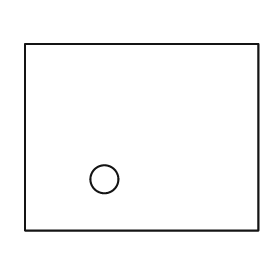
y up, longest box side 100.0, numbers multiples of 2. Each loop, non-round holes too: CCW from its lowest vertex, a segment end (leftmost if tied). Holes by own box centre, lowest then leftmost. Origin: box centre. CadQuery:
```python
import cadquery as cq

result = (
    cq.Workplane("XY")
    .moveTo(-50.0, -40.0)
    .lineTo(50.0, -40.0)
    .lineTo(50.0, 40.0)
    .lineTo(-50.0, 40.0)
    .close()
    .moveTo(-16.0, -18.0)
    .circle(6.0)
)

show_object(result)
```